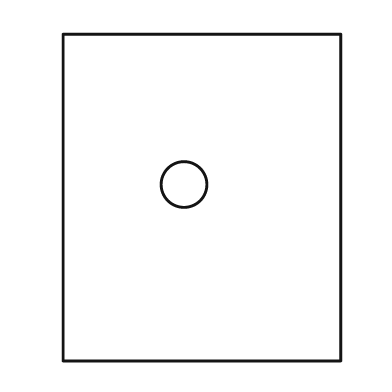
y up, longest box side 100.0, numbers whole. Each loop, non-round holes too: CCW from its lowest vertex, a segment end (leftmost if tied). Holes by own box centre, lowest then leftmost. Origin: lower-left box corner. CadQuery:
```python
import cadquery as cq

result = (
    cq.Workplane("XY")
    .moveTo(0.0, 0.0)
    .lineTo(85.0, 0.0)
    .lineTo(85.0, 100.0)
    .lineTo(0.0, 100.0)
    .close()
    .moveTo(37.0, 54.0)
    .circle(7.0)
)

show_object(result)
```